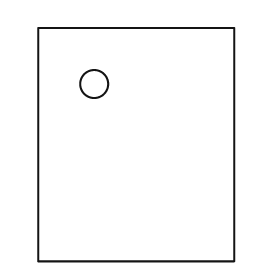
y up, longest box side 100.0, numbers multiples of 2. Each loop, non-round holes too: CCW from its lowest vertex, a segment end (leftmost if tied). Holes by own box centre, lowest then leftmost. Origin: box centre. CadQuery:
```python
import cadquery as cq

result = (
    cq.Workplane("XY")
    .moveTo(-42.0, -50.0)
    .lineTo(42.0, -50.0)
    .lineTo(42.0, 50.0)
    .lineTo(-42.0, 50.0)
    .close()
    .moveTo(-18.0, 26.0)
    .circle(6.0)
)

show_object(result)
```